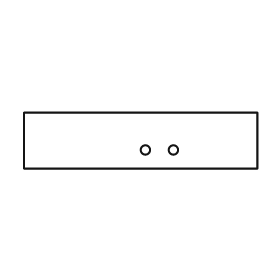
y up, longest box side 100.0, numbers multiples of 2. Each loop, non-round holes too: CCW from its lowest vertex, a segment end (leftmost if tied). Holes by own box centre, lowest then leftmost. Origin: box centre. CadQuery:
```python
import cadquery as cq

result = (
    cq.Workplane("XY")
    .moveTo(-50.0, -12.0)
    .lineTo(50.0, -12.0)
    .lineTo(50.0, 12.0)
    .lineTo(-50.0, 12.0)
    .close()
    .moveTo(2.0, -4.0)
    .circle(2.0)
    .moveTo(14.0, -4.0)
    .circle(2.0)
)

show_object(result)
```